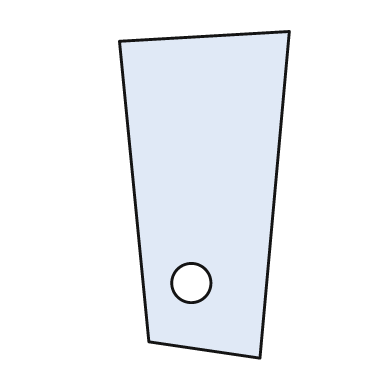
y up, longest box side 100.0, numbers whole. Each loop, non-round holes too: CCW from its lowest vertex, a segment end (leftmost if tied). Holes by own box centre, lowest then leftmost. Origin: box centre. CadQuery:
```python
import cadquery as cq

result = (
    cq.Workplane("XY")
    .moveTo(17.0, -50.0)
    .lineTo(26.0, 50.0)
    .lineTo(-26.0, 47.0)
    .lineTo(-17.0, -45.0)
    .close()
    .moveTo(-4.0, -27.0)
    .circle(6.0)
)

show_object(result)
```